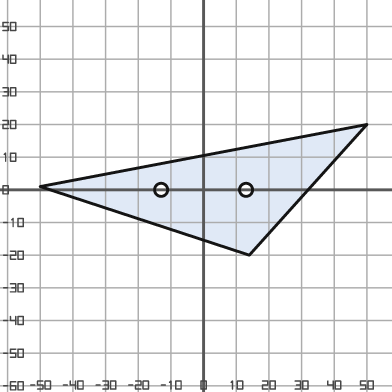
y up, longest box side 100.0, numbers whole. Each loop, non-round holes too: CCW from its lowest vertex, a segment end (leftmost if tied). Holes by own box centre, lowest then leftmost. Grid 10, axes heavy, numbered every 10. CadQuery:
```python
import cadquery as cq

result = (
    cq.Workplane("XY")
    .moveTo(14.0, -20.0)
    .lineTo(50.0, 20.0)
    .lineTo(-50.0, 1.0)
    .close()
    .moveTo(-13.0, 0.0)
    .circle(2.0)
    .moveTo(13.0, 0.0)
    .circle(2.0)
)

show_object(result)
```